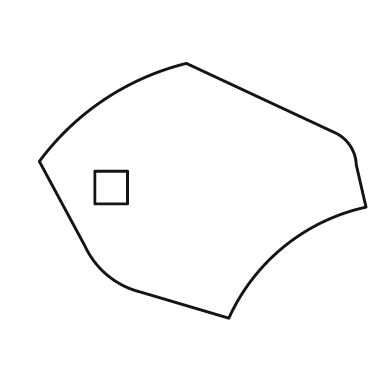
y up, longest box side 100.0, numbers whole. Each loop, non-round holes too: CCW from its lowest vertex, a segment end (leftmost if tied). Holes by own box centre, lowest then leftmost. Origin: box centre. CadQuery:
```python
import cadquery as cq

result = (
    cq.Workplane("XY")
    .moveTo(8.0, -39.0)
    .threePointArc((25.0, -17.0), (50.0, -5.0))
    .lineTo(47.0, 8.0)
    .threePointArc((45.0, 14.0), (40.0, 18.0))
    .lineTo(-5.0, 39.0)
    .threePointArc((-30.0, 28.0), (-50.0, 9.0))
    .lineTo(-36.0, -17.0)
    .threePointArc((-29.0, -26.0), (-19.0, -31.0))
    .close()
    .moveTo(-33.0, -4.0)
    .lineTo(-23.0, -4.0)
    .lineTo(-23.0, 6.0)
    .lineTo(-33.0, 6.0)
    .close()
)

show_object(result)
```